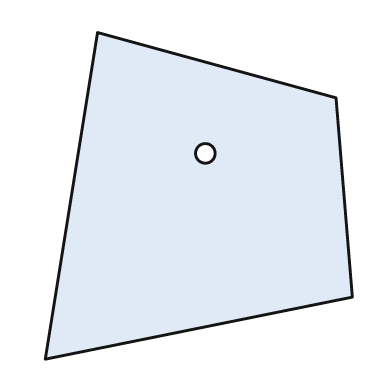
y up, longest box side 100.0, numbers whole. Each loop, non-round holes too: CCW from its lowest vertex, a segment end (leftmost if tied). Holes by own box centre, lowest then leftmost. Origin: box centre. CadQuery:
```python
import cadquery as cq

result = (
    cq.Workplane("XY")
    .moveTo(-47.0, -50.0)
    .lineTo(47.0, -31.0)
    .lineTo(42.0, 30.0)
    .lineTo(-31.0, 50.0)
    .close()
    .moveTo(2.0, 13.0)
    .circle(3.0)
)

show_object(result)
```